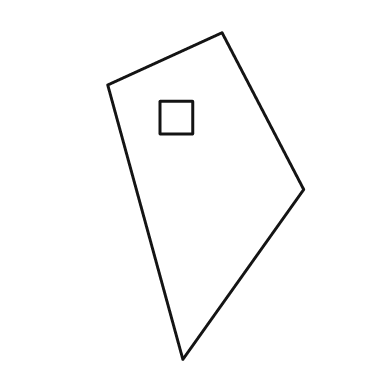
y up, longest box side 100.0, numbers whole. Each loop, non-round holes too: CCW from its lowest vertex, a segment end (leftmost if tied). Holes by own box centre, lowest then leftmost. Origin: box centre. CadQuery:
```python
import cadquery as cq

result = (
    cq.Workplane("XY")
    .moveTo(-7.0, -50.0)
    .lineTo(30.0, 2.0)
    .lineTo(5.0, 50.0)
    .lineTo(-30.0, 34.0)
    .close()
    .moveTo(-14.0, 19.0)
    .lineTo(-4.0, 19.0)
    .lineTo(-4.0, 29.0)
    .lineTo(-14.0, 29.0)
    .close()
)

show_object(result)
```